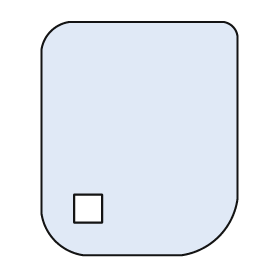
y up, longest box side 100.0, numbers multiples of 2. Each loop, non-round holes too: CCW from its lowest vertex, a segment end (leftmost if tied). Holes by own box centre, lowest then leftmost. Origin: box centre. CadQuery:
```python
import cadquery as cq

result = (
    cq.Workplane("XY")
    .moveTo(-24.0, -50.0)
    .lineTo(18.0, -50.0)
    .threePointArc((34.0, -42.0), (42.0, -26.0))
    .lineTo(42.0, 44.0)
    .threePointArc((40.0, 48.0), (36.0, 50.0))
    .lineTo(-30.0, 50.0)
    .threePointArc((-38.0, 46.0), (-42.0, 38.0))
    .lineTo(-42.0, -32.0)
    .threePointArc((-36.0, -44.0), (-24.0, -50.0))
    .close()
    .moveTo(-28.0, -36.0)
    .lineTo(-16.0, -36.0)
    .lineTo(-16.0, -24.0)
    .lineTo(-28.0, -24.0)
    .close()
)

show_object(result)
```